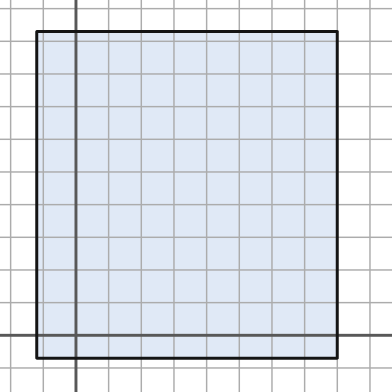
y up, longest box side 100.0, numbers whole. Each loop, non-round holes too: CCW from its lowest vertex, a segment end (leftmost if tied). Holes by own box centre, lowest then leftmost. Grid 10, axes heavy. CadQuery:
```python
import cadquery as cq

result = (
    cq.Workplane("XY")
    .moveTo(-12.0, -7.0)
    .lineTo(80.0, -7.0)
    .lineTo(80.0, 93.0)
    .lineTo(-12.0, 93.0)
    .close()
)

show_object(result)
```